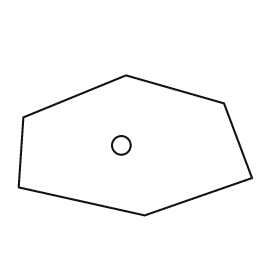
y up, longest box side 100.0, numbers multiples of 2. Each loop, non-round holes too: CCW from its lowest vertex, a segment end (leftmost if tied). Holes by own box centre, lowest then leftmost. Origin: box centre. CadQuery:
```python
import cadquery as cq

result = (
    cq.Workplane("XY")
    .moveTo(4.0, -30.0)
    .lineTo(50.0, -14.0)
    .lineTo(38.0, 18.0)
    .lineTo(-4.0, 30.0)
    .lineTo(-48.0, 12.0)
    .lineTo(-50.0, -18.0)
    .close()
    .moveTo(-6.0, 0.0)
    .circle(4.0)
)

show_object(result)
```